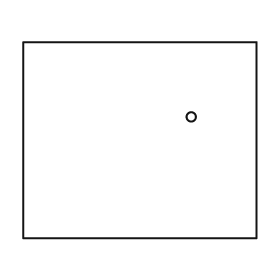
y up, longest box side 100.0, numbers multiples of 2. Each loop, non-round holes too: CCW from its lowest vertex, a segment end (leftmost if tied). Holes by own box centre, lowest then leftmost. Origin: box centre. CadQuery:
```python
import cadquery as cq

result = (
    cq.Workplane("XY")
    .moveTo(-50.0, -42.0)
    .lineTo(50.0, -42.0)
    .lineTo(50.0, 42.0)
    .lineTo(-50.0, 42.0)
    .close()
    .moveTo(22.0, 10.0)
    .circle(2.0)
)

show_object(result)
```